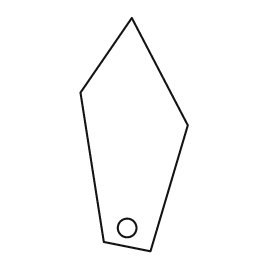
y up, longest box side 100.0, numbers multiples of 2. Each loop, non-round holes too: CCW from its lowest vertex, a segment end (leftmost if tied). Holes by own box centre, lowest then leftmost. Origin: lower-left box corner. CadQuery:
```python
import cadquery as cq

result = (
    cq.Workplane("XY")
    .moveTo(30.0, 0.0)
    .lineTo(46.0, 54.0)
    .lineTo(22.0, 100.0)
    .lineTo(0.0, 68.0)
    .lineTo(10.0, 4.0)
    .close()
    .moveTo(20.0, 10.0)
    .circle(4.0)
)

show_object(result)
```